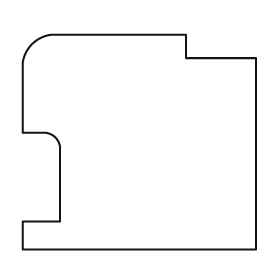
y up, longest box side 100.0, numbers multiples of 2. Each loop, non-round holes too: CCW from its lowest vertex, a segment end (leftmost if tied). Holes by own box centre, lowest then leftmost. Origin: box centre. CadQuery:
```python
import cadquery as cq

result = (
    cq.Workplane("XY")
    .moveTo(-50.0, -46.0)
    .lineTo(50.0, -46.0)
    .lineTo(50.0, 36.0)
    .lineTo(20.0, 36.0)
    .lineTo(20.0, 46.0)
    .lineTo(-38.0, 46.0)
    .threePointArc((-46.0, 42.0), (-50.0, 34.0))
    .lineTo(-50.0, 4.0)
    .lineTo(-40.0, 4.0)
    .threePointArc((-36.0, 2.0), (-34.0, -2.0))
    .lineTo(-34.0, -34.0)
    .lineTo(-50.0, -34.0)
    .close()
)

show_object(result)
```